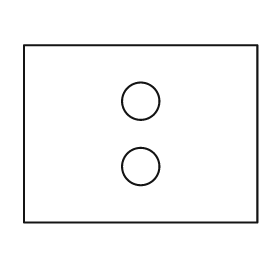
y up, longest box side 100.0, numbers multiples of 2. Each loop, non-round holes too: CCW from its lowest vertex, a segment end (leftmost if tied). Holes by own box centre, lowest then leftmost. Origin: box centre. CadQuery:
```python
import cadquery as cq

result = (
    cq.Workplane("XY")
    .moveTo(-50.0, -38.0)
    .lineTo(50.0, -38.0)
    .lineTo(50.0, 38.0)
    .lineTo(-50.0, 38.0)
    .close()
    .moveTo(0.0, -14.0)
    .circle(8.0)
    .moveTo(0.0, 14.0)
    .circle(8.0)
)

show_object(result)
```